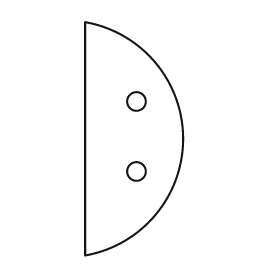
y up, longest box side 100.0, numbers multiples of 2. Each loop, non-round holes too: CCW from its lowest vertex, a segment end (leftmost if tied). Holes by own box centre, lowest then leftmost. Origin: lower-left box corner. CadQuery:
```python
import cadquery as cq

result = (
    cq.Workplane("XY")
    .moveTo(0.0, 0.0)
    .threePointArc((42.0, 50.0), (0.0, 100.0))
    .close()
    .moveTo(22.0, 36.0)
    .circle(4.0)
    .moveTo(22.0, 66.0)
    .circle(4.0)
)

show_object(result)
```